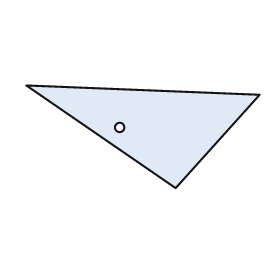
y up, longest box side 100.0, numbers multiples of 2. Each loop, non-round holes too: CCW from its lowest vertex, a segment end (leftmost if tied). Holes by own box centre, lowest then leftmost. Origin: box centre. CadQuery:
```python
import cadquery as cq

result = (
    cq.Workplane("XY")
    .moveTo(14.0, -22.0)
    .lineTo(50.0, 18.0)
    .lineTo(-50.0, 22.0)
    .close()
    .moveTo(-10.0, 4.0)
    .circle(2.0)
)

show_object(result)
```